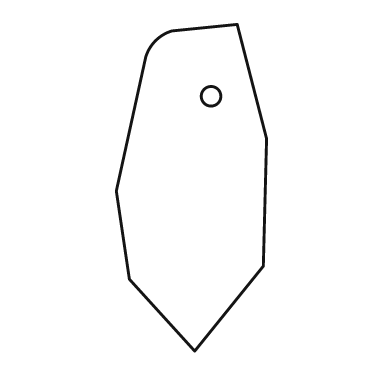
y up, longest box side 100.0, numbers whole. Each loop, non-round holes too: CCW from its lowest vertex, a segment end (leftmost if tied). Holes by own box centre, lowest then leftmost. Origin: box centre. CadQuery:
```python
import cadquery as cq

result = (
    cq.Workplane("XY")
    .moveTo(1.0, -50.0)
    .lineTo(22.0, -24.0)
    .lineTo(23.0, 15.0)
    .lineTo(14.0, 50.0)
    .lineTo(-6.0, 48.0)
    .threePointArc((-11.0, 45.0), (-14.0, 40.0))
    .lineTo(-23.0, -1.0)
    .lineTo(-19.0, -28.0)
    .close()
    .moveTo(6.0, 28.0)
    .circle(3.0)
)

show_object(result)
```